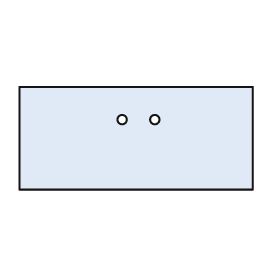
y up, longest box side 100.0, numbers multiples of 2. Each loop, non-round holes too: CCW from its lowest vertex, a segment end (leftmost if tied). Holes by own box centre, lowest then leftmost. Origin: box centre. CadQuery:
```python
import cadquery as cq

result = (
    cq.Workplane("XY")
    .moveTo(-50.0, -22.0)
    .lineTo(50.0, -22.0)
    .lineTo(50.0, 22.0)
    .lineTo(-50.0, 22.0)
    .close()
    .moveTo(-6.0, 8.0)
    .circle(2.0)
    .moveTo(8.0, 8.0)
    .circle(2.0)
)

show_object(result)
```